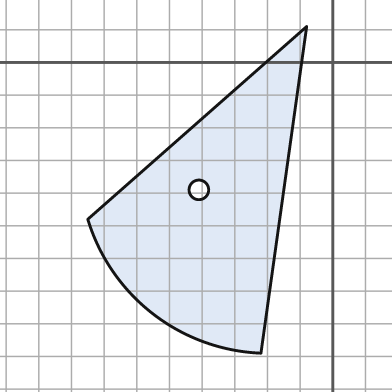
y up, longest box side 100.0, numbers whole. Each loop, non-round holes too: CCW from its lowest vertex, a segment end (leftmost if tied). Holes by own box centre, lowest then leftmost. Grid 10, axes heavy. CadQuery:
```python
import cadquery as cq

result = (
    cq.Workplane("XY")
    .moveTo(-22.0, -89.0)
    .lineTo(-8.0, 11.0)
    .lineTo(-75.0, -48.0)
    .threePointArc((-55.0, -77.0), (-22.0, -89.0))
    .close()
    .moveTo(-41.0, -39.0)
    .circle(3.0)
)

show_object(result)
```